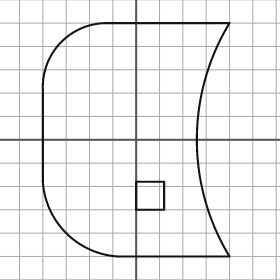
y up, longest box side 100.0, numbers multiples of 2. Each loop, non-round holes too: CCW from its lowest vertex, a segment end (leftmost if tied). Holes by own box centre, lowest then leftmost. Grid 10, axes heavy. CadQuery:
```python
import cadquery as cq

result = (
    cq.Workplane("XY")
    .moveTo(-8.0, -50.0)
    .lineTo(40.0, -50.0)
    .threePointArc((26.0, 0.0), (40.0, 50.0))
    .lineTo(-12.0, 50.0)
    .threePointArc((-32.0, 42.0), (-40.0, 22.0))
    .lineTo(-40.0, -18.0)
    .threePointArc((-30.0, -40.0), (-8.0, -50.0))
    .close()
    .moveTo(0.0, -30.0)
    .lineTo(12.0, -30.0)
    .lineTo(12.0, -18.0)
    .lineTo(0.0, -18.0)
    .close()
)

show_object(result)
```